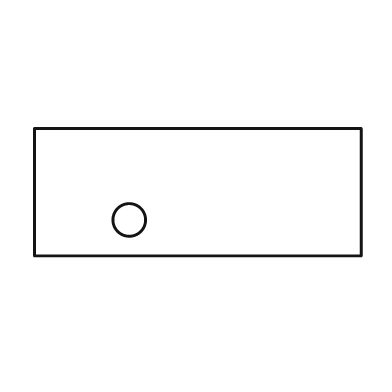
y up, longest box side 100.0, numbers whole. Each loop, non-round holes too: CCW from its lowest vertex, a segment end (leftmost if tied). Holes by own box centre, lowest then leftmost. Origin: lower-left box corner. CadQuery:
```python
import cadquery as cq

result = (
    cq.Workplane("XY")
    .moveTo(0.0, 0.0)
    .lineTo(100.0, 0.0)
    .lineTo(100.0, 39.0)
    .lineTo(0.0, 39.0)
    .close()
    .moveTo(29.0, 11.0)
    .circle(5.0)
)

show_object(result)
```